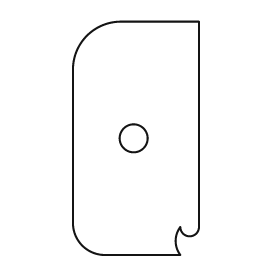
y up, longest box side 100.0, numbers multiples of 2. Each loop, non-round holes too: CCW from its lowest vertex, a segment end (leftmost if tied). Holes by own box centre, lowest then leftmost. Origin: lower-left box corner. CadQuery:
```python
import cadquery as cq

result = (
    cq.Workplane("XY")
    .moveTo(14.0, 0.0)
    .lineTo(46.0, 0.0)
    .threePointArc((44.0, 6.0), (46.0, 12.0))
    .threePointArc((50.0, 8.0), (54.0, 12.0))
    .lineTo(54.0, 100.0)
    .lineTo(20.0, 100.0)
    .threePointArc((6.0, 94.0), (0.0, 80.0))
    .lineTo(0.0, 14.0)
    .threePointArc((4.0, 4.0), (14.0, 0.0))
    .close()
    .moveTo(26.0, 50.0)
    .circle(6.0)
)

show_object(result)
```